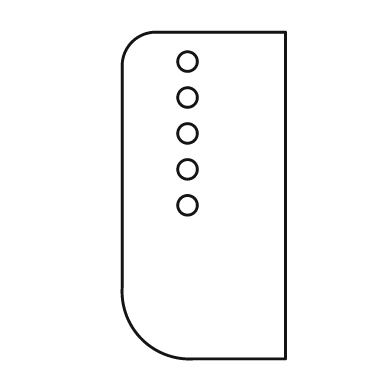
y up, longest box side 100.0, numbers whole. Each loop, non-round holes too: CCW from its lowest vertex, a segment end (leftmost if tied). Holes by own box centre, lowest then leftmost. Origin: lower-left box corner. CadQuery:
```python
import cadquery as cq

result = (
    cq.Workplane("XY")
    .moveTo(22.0, 0.0)
    .lineTo(50.0, 0.0)
    .lineTo(50.0, 100.0)
    .lineTo(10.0, 100.0)
    .threePointArc((3.0, 97.0), (0.0, 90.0))
    .lineTo(0.0, 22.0)
    .threePointArc((6.0, 6.0), (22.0, 0.0))
    .close()
    .moveTo(20.0, 47.0)
    .circle(3.0)
    .moveTo(20.0, 58.0)
    .circle(3.0)
    .moveTo(20.0, 69.0)
    .circle(3.0)
    .moveTo(20.0, 80.0)
    .circle(3.0)
    .moveTo(20.0, 91.0)
    .circle(3.0)
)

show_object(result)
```